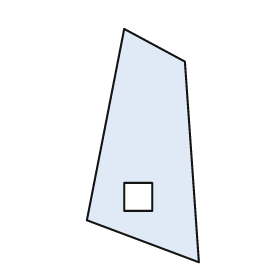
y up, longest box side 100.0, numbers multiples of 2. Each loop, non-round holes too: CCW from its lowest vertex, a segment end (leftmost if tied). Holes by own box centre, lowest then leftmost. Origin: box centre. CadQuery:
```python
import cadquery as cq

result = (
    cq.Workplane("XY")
    .moveTo(24.0, -50.0)
    .lineTo(18.0, 36.0)
    .lineTo(-8.0, 50.0)
    .lineTo(-24.0, -32.0)
    .close()
    .moveTo(-8.0, -28.0)
    .lineTo(4.0, -28.0)
    .lineTo(4.0, -16.0)
    .lineTo(-8.0, -16.0)
    .close()
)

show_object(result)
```